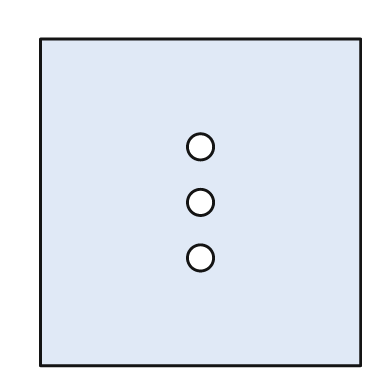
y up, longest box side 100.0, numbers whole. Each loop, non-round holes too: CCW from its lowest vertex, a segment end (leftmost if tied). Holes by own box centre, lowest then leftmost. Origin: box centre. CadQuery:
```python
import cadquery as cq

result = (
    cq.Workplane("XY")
    .moveTo(-49.0, -50.0)
    .lineTo(49.0, -50.0)
    .lineTo(49.0, 50.0)
    .lineTo(-49.0, 50.0)
    .close()
    .moveTo(0.0, -17.0)
    .circle(4.0)
    .moveTo(0.0, 0.0)
    .circle(4.0)
    .moveTo(0.0, 17.0)
    .circle(4.0)
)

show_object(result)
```